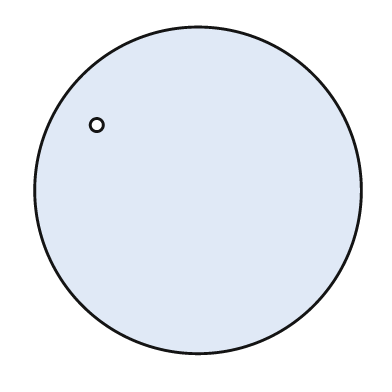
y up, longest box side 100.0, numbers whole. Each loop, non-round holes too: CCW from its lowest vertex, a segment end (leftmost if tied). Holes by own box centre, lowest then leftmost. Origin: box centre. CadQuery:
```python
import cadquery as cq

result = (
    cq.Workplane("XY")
    .moveTo(0.0, 0.0)
    .circle(50.0)
    .moveTo(-31.0, 20.0)
    .circle(2.0)
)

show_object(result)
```